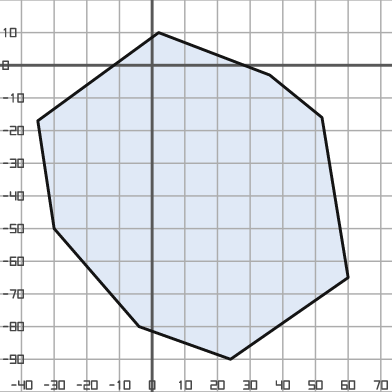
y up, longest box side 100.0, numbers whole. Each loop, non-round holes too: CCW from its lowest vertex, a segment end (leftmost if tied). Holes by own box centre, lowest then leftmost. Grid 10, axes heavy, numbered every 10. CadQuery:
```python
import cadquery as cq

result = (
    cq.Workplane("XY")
    .moveTo(24.0, -90.0)
    .lineTo(60.0, -65.0)
    .lineTo(52.0, -16.0)
    .lineTo(36.0, -3.0)
    .lineTo(2.0, 10.0)
    .lineTo(-35.0, -17.0)
    .lineTo(-30.0, -50.0)
    .lineTo(-4.0, -80.0)
    .close()
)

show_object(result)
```